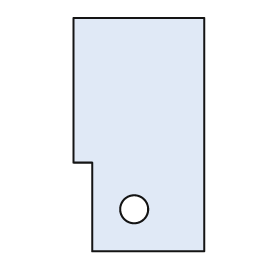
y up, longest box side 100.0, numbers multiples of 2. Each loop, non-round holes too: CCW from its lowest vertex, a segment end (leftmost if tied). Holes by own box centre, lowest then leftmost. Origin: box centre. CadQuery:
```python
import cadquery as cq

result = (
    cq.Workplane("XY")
    .moveTo(-20.0, -50.0)
    .lineTo(28.0, -50.0)
    .lineTo(28.0, 50.0)
    .lineTo(-28.0, 50.0)
    .lineTo(-28.0, -12.0)
    .lineTo(-20.0, -12.0)
    .close()
    .moveTo(-2.0, -32.0)
    .circle(6.0)
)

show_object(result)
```